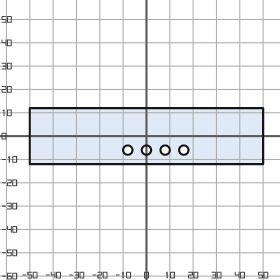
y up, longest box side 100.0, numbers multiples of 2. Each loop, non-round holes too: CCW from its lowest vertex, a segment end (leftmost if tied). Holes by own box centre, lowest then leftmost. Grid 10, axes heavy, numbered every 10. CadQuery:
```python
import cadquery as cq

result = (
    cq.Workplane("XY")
    .moveTo(-50.0, -12.0)
    .lineTo(50.0, -12.0)
    .lineTo(50.0, 12.0)
    .lineTo(-50.0, 12.0)
    .close()
    .moveTo(-8.0, -6.0)
    .circle(2.0)
    .moveTo(0.0, -6.0)
    .circle(2.0)
    .moveTo(8.0, -6.0)
    .circle(2.0)
    .moveTo(16.0, -6.0)
    .circle(2.0)
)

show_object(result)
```